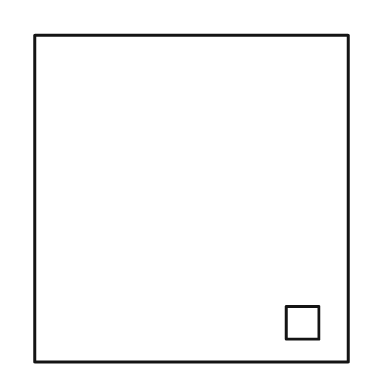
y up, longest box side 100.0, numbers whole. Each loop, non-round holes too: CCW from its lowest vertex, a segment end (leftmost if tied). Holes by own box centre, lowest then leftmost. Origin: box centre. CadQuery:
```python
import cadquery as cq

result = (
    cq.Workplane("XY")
    .moveTo(-48.0, -50.0)
    .lineTo(48.0, -50.0)
    .lineTo(48.0, 50.0)
    .lineTo(-48.0, 50.0)
    .close()
    .moveTo(29.0, -43.0)
    .lineTo(39.0, -43.0)
    .lineTo(39.0, -33.0)
    .lineTo(29.0, -33.0)
    .close()
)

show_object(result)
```